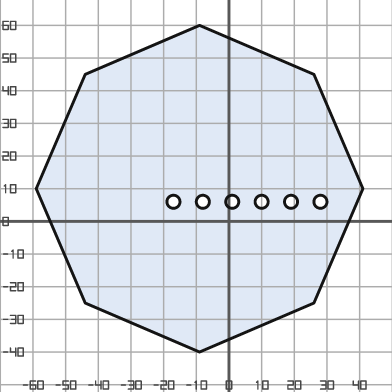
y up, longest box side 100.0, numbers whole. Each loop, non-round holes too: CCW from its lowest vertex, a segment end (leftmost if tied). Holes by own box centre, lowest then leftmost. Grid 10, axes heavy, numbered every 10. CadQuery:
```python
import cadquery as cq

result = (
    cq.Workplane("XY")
    .moveTo(-9.0, -40.0)
    .lineTo(26.0, -25.0)
    .lineTo(41.0, 10.0)
    .lineTo(26.0, 45.0)
    .lineTo(-9.0, 60.0)
    .lineTo(-44.0, 45.0)
    .lineTo(-59.0, 10.0)
    .lineTo(-44.0, -25.0)
    .close()
    .moveTo(-17.0, 6.0)
    .circle(2.0)
    .moveTo(-8.0, 6.0)
    .circle(2.0)
    .moveTo(1.0, 6.0)
    .circle(2.0)
    .moveTo(10.0, 6.0)
    .circle(2.0)
    .moveTo(19.0, 6.0)
    .circle(2.0)
    .moveTo(28.0, 6.0)
    .circle(2.0)
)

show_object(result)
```